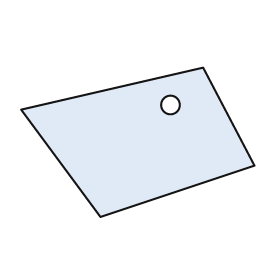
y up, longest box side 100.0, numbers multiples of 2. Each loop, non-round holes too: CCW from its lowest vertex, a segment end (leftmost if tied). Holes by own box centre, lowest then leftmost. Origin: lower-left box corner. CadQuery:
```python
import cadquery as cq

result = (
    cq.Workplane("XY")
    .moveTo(34.0, 0.0)
    .lineTo(100.0, 22.0)
    .lineTo(78.0, 64.0)
    .lineTo(0.0, 46.0)
    .close()
    .moveTo(64.0, 48.0)
    .circle(4.0)
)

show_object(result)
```